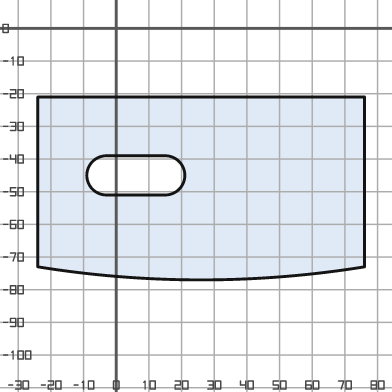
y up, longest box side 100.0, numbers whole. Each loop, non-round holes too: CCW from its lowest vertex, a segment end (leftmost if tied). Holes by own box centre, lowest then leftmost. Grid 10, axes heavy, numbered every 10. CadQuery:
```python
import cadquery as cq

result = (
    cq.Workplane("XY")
    .moveTo(-24.0, -73.0)
    .threePointArc((26.0, -77.0), (76.0, -73.0))
    .lineTo(76.0, -21.0)
    .lineTo(-24.0, -21.0)
    .close()
    .moveTo(-3.0, -51.0)
    .lineTo(15.0, -51.0)
    .threePointArc((21.0, -45.0), (15.0, -39.0))
    .lineTo(-3.0, -39.0)
    .threePointArc((-9.0, -45.0), (-3.0, -51.0))
    .close()
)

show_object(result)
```